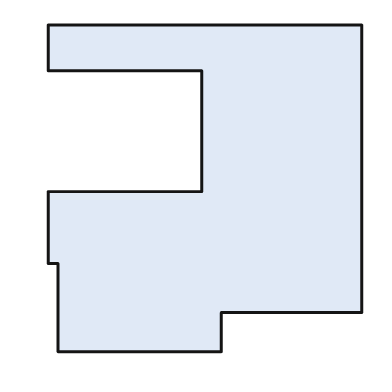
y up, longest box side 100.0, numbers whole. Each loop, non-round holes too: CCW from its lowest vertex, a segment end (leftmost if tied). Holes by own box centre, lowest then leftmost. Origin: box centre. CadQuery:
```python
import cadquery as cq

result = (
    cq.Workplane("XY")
    .moveTo(-45.0, -50.0)
    .lineTo(5.0, -50.0)
    .lineTo(5.0, -38.0)
    .lineTo(48.0, -38.0)
    .lineTo(48.0, 50.0)
    .lineTo(-48.0, 50.0)
    .lineTo(-48.0, 36.0)
    .lineTo(-1.0, 36.0)
    .lineTo(-1.0, -1.0)
    .lineTo(-48.0, -1.0)
    .lineTo(-48.0, -23.0)
    .lineTo(-45.0, -23.0)
    .close()
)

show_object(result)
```